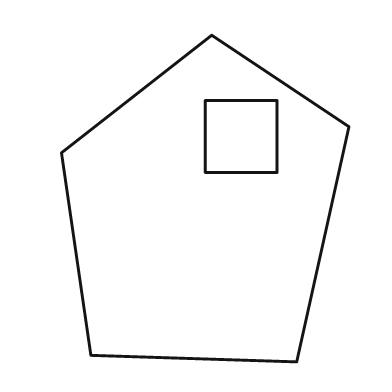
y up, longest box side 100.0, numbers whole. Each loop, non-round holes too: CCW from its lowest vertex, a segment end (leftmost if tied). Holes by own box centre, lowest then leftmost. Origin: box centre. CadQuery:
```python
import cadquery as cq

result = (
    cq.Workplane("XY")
    .moveTo(28.0, -50.0)
    .lineTo(44.0, 22.0)
    .lineTo(2.0, 50.0)
    .lineTo(-44.0, 14.0)
    .lineTo(-35.0, -48.0)
    .close()
    .moveTo(0.0, 8.0)
    .lineTo(22.0, 8.0)
    .lineTo(22.0, 30.0)
    .lineTo(0.0, 30.0)
    .close()
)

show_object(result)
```